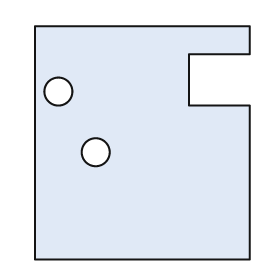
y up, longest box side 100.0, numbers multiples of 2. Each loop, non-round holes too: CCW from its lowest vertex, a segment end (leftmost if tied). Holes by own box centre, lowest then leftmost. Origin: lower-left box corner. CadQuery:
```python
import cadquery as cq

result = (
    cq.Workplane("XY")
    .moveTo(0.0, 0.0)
    .lineTo(92.0, 0.0)
    .lineTo(92.0, 66.0)
    .lineTo(66.0, 66.0)
    .lineTo(66.0, 88.0)
    .lineTo(92.0, 88.0)
    .lineTo(92.0, 100.0)
    .lineTo(0.0, 100.0)
    .close()
    .moveTo(26.0, 46.0)
    .circle(6.0)
    .moveTo(10.0, 72.0)
    .circle(6.0)
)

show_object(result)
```